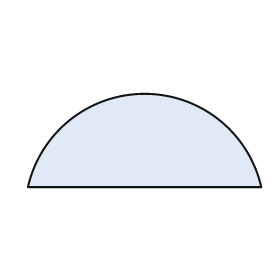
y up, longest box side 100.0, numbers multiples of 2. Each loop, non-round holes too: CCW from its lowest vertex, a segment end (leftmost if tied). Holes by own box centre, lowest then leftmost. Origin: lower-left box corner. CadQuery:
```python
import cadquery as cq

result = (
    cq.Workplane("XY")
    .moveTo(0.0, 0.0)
    .lineTo(100.0, 0.0)
    .threePointArc((50.0, 40.0), (0.0, 0.0))
    .close()
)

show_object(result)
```